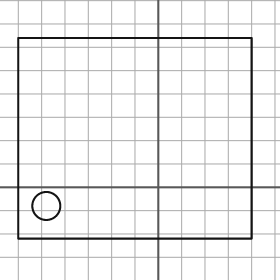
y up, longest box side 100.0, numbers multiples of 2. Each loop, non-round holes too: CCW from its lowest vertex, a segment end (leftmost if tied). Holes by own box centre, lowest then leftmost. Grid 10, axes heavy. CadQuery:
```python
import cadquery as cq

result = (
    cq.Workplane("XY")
    .moveTo(-60.0, -22.0)
    .lineTo(40.0, -22.0)
    .lineTo(40.0, 64.0)
    .lineTo(-60.0, 64.0)
    .close()
    .moveTo(-48.0, -8.0)
    .circle(6.0)
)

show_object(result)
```